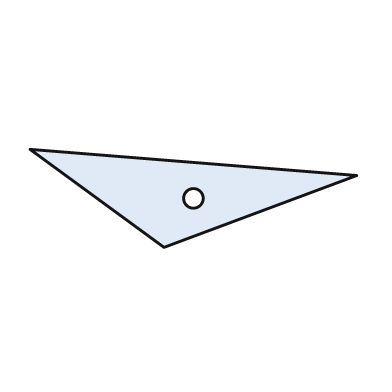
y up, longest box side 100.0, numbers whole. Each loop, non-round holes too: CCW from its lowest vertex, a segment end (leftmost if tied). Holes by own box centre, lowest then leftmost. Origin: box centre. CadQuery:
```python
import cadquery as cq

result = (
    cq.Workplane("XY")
    .moveTo(-9.0, -15.0)
    .lineTo(50.0, 7.0)
    .lineTo(-50.0, 15.0)
    .close()
    .moveTo(0.0, 0.0)
    .circle(3.0)
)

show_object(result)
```